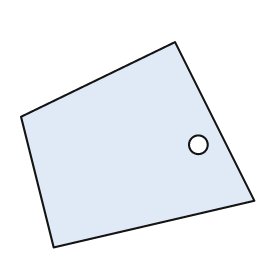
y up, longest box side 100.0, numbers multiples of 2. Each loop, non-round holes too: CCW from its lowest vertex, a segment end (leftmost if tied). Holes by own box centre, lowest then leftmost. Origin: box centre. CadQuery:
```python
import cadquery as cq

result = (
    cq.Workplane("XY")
    .moveTo(-36.0, -44.0)
    .lineTo(50.0, -24.0)
    .lineTo(16.0, 44.0)
    .lineTo(-50.0, 12.0)
    .close()
    .moveTo(26.0, 0.0)
    .circle(4.0)
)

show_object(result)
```